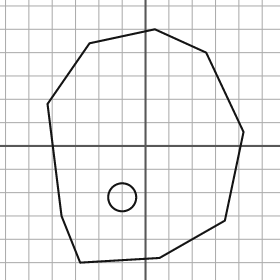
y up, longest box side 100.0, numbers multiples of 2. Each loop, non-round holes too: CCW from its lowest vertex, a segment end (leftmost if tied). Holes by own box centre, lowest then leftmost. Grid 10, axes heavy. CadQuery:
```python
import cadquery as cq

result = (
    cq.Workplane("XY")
    .moveTo(-28.0, -50.0)
    .lineTo(6.0, -48.0)
    .lineTo(34.0, -32.0)
    .lineTo(42.0, 6.0)
    .lineTo(26.0, 40.0)
    .lineTo(4.0, 50.0)
    .lineTo(-24.0, 44.0)
    .lineTo(-42.0, 18.0)
    .lineTo(-36.0, -30.0)
    .close()
    .moveTo(-10.0, -22.0)
    .circle(6.0)
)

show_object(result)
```